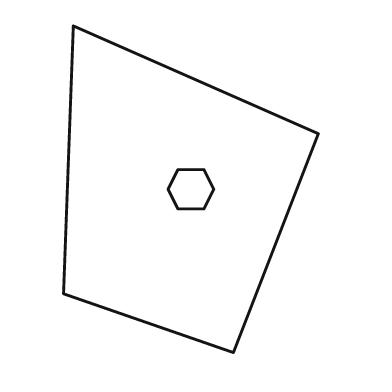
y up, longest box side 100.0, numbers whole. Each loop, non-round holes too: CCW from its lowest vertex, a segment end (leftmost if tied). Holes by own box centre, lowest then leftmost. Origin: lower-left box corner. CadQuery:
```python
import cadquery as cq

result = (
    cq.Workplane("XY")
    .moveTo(52.0, 0.0)
    .lineTo(78.0, 67.0)
    .lineTo(3.0, 100.0)
    .lineTo(0.0, 18.0)
    .close()
    .moveTo(35.0, 44.0)
    .lineTo(43.0, 44.0)
    .lineTo(46.0, 50.0)
    .lineTo(43.0, 56.0)
    .lineTo(35.0, 56.0)
    .lineTo(32.0, 50.0)
    .close()
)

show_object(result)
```